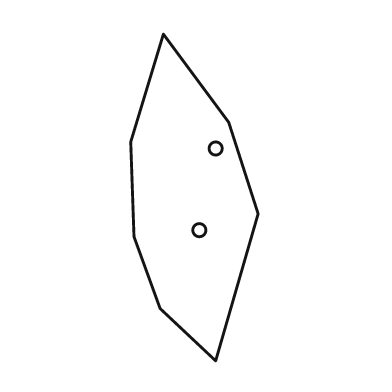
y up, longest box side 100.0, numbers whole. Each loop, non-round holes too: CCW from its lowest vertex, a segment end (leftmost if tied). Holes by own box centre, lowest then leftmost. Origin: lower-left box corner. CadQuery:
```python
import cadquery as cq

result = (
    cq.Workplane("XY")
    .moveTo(26.0, 0.0)
    .lineTo(39.0, 45.0)
    .lineTo(30.0, 73.0)
    .lineTo(10.0, 100.0)
    .lineTo(0.0, 67.0)
    .lineTo(1.0, 38.0)
    .lineTo(9.0, 16.0)
    .close()
    .moveTo(21.0, 40.0)
    .circle(2.0)
    .moveTo(26.0, 65.0)
    .circle(2.0)
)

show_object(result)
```